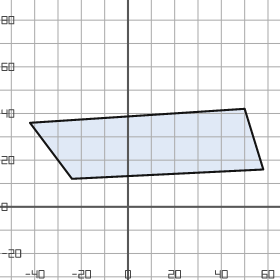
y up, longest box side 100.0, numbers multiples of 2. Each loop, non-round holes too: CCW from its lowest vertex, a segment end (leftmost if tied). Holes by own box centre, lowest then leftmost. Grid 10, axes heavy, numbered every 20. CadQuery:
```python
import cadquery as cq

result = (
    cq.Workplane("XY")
    .moveTo(-24.0, 12.0)
    .lineTo(58.0, 16.0)
    .lineTo(50.0, 42.0)
    .lineTo(-42.0, 36.0)
    .close()
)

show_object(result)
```